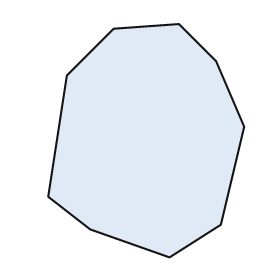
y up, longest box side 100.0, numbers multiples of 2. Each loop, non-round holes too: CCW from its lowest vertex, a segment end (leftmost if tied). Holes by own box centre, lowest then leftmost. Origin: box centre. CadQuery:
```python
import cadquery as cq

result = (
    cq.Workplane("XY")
    .moveTo(10.0, -50.0)
    .lineTo(32.0, -36.0)
    .lineTo(42.0, 6.0)
    .lineTo(30.0, 34.0)
    .lineTo(14.0, 50.0)
    .lineTo(-14.0, 48.0)
    .lineTo(-34.0, 28.0)
    .lineTo(-42.0, -24.0)
    .lineTo(-24.0, -38.0)
    .close()
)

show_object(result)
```